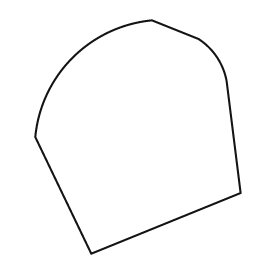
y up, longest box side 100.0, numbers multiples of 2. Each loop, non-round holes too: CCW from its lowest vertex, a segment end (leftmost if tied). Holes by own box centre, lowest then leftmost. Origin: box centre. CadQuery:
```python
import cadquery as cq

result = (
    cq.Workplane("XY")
    .moveTo(-20.0, -50.0)
    .lineTo(44.0, -24.0)
    .lineTo(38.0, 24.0)
    .threePointArc((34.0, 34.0), (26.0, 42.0))
    .lineTo(6.0, 50.0)
    .threePointArc((-28.0, 34.0), (-44.0, 0.0))
    .close()
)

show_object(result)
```